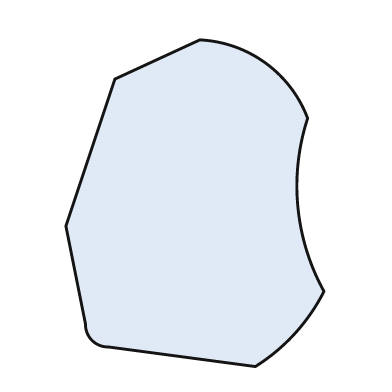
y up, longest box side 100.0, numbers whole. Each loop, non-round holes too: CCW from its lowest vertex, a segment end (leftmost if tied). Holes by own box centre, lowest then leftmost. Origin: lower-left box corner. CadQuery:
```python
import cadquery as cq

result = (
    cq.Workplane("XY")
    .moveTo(58.0, 0.0)
    .threePointArc((70.0, 10.0), (79.0, 23.0))
    .threePointArc((71.0, 49.0), (74.0, 76.0))
    .threePointArc((61.0, 93.0), (41.0, 100.0))
    .lineTo(15.0, 88.0)
    .lineTo(0.0, 43.0)
    .lineTo(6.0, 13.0)
    .threePointArc((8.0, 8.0), (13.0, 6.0))
    .close()
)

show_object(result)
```